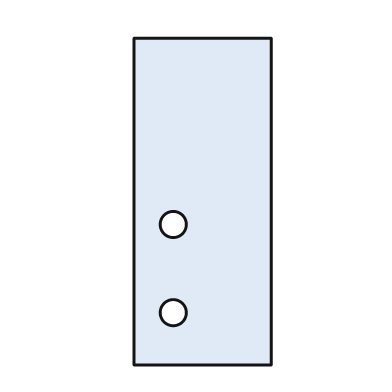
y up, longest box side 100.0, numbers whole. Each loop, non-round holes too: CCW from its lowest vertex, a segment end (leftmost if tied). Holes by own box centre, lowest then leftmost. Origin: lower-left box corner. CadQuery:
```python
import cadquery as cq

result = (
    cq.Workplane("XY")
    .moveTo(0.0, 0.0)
    .lineTo(42.0, 0.0)
    .lineTo(42.0, 100.0)
    .lineTo(0.0, 100.0)
    .close()
    .moveTo(12.0, 16.0)
    .circle(4.0)
    .moveTo(12.0, 43.0)
    .circle(4.0)
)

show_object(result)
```